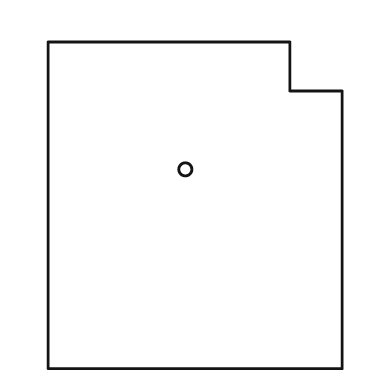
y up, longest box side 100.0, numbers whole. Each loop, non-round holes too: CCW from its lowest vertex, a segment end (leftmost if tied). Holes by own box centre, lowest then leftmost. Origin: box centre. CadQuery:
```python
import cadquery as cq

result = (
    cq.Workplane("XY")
    .moveTo(-45.0, -50.0)
    .lineTo(45.0, -50.0)
    .lineTo(45.0, 35.0)
    .lineTo(29.0, 35.0)
    .lineTo(29.0, 50.0)
    .lineTo(-45.0, 50.0)
    .close()
    .moveTo(-3.0, 11.0)
    .circle(2.0)
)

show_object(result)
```